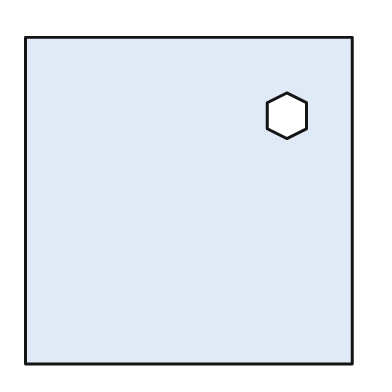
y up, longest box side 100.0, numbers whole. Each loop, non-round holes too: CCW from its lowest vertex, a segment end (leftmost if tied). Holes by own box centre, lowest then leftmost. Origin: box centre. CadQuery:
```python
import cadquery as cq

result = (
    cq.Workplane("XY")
    .moveTo(-50.0, -50.0)
    .lineTo(50.0, -50.0)
    .lineTo(50.0, 50.0)
    .lineTo(-50.0, 50.0)
    .close()
    .moveTo(30.0, 19.0)
    .lineTo(36.0, 22.0)
    .lineTo(36.0, 30.0)
    .lineTo(30.0, 33.0)
    .lineTo(24.0, 30.0)
    .lineTo(24.0, 22.0)
    .close()
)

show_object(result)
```